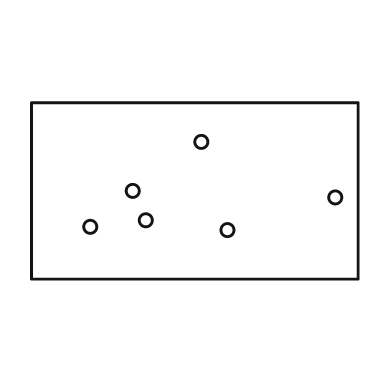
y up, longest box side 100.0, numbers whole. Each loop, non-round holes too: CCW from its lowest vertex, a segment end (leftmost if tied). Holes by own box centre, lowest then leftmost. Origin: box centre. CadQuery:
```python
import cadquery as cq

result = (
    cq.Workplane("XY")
    .moveTo(-50.0, -27.0)
    .lineTo(50.0, -27.0)
    .lineTo(50.0, 27.0)
    .lineTo(-50.0, 27.0)
    .close()
    .moveTo(10.0, -12.0)
    .circle(2.0)
    .moveTo(-32.0, -11.0)
    .circle(2.0)
    .moveTo(-15.0, -9.0)
    .circle(2.0)
    .moveTo(43.0, -2.0)
    .circle(2.0)
    .moveTo(-19.0, 0.0)
    .circle(2.0)
    .moveTo(2.0, 15.0)
    .circle(2.0)
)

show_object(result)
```